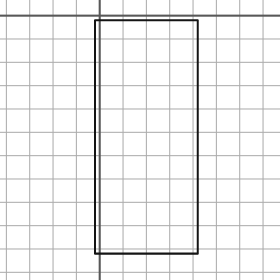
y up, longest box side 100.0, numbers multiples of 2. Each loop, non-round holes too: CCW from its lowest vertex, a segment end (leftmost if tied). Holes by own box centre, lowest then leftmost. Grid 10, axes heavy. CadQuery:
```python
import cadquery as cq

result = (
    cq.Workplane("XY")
    .moveTo(-2.0, -102.0)
    .lineTo(42.0, -102.0)
    .lineTo(42.0, -2.0)
    .lineTo(-2.0, -2.0)
    .close()
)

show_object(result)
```